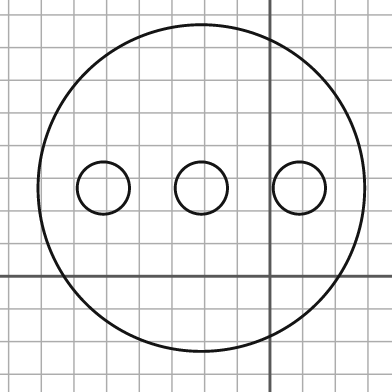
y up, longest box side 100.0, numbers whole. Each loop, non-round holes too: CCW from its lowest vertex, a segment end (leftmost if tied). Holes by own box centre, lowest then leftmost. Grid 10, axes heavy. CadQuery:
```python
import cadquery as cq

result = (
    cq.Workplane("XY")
    .moveTo(-21.0, 27.0)
    .circle(50.0)
    .moveTo(-51.0, 27.0)
    .circle(8.0)
    .moveTo(-21.0, 27.0)
    .circle(8.0)
    .moveTo(9.0, 27.0)
    .circle(8.0)
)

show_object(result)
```